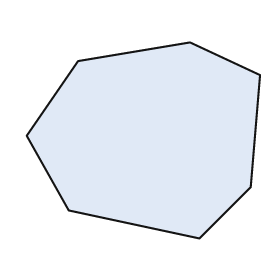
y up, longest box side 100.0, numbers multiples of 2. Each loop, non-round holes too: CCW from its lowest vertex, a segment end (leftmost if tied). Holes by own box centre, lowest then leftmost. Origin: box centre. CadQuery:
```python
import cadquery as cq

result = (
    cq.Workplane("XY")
    .moveTo(24.0, -42.0)
    .lineTo(46.0, -20.0)
    .lineTo(50.0, 28.0)
    .lineTo(20.0, 42.0)
    .lineTo(-28.0, 34.0)
    .lineTo(-50.0, 2.0)
    .lineTo(-32.0, -30.0)
    .close()
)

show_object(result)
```